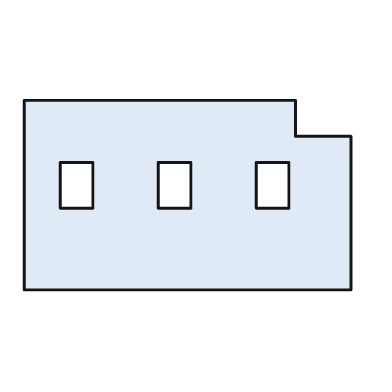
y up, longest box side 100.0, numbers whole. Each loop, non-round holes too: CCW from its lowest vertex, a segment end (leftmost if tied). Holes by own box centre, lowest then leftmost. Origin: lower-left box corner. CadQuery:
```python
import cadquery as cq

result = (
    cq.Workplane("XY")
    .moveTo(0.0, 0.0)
    .lineTo(100.0, 0.0)
    .lineTo(100.0, 47.0)
    .lineTo(83.0, 47.0)
    .lineTo(83.0, 58.0)
    .lineTo(0.0, 58.0)
    .close()
    .moveTo(11.0, 25.0)
    .lineTo(21.0, 25.0)
    .lineTo(21.0, 39.0)
    .lineTo(11.0, 39.0)
    .close()
    .moveTo(41.0, 25.0)
    .lineTo(51.0, 25.0)
    .lineTo(51.0, 39.0)
    .lineTo(41.0, 39.0)
    .close()
    .moveTo(71.0, 25.0)
    .lineTo(81.0, 25.0)
    .lineTo(81.0, 39.0)
    .lineTo(71.0, 39.0)
    .close()
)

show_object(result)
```